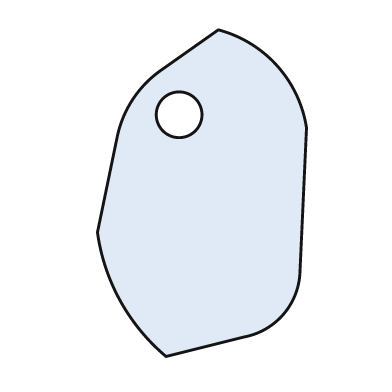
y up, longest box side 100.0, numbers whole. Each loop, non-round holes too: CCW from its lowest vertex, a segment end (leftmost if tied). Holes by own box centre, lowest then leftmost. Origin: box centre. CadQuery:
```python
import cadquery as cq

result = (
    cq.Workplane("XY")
    .moveTo(-11.0, -50.0)
    .lineTo(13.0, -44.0)
    .threePointArc((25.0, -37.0), (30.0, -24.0))
    .lineTo(32.0, 20.0)
    .threePointArc((23.0, 39.0), (5.0, 50.0))
    .lineTo(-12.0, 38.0)
    .threePointArc((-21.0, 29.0), (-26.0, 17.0))
    .lineTo(-32.0, -12.0)
    .threePointArc((-25.0, -33.0), (-11.0, -50.0))
    .close()
    .moveTo(-7.0, 24.0)
    .circle(7.0)
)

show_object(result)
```